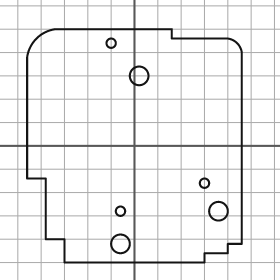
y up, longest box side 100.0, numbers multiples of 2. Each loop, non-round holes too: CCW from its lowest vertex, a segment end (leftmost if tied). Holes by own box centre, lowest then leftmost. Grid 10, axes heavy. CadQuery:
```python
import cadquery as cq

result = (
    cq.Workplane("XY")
    .moveTo(-30.0, -50.0)
    .lineTo(30.0, -50.0)
    .lineTo(30.0, -46.0)
    .lineTo(40.0, -46.0)
    .lineTo(40.0, -42.0)
    .lineTo(46.0, -42.0)
    .lineTo(46.0, 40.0)
    .threePointArc((44.0, 44.0), (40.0, 46.0))
    .lineTo(16.0, 46.0)
    .lineTo(16.0, 50.0)
    .lineTo(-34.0, 50.0)
    .threePointArc((-42.0, 46.0), (-46.0, 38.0))
    .lineTo(-46.0, -14.0)
    .lineTo(-38.0, -14.0)
    .lineTo(-38.0, -40.0)
    .lineTo(-30.0, -40.0)
    .close()
    .moveTo(-6.0, -42.0)
    .circle(4.0)
    .moveTo(-6.0, -28.0)
    .circle(2.0)
    .moveTo(36.0, -28.0)
    .circle(4.0)
    .moveTo(30.0, -16.0)
    .circle(2.0)
    .moveTo(2.0, 30.0)
    .circle(4.0)
    .moveTo(-10.0, 44.0)
    .circle(2.0)
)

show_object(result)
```